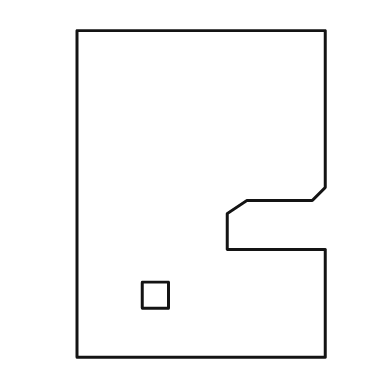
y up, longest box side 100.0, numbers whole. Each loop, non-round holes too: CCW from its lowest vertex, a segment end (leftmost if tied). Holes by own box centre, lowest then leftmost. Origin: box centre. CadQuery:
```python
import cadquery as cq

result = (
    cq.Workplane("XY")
    .moveTo(-38.0, -50.0)
    .lineTo(38.0, -50.0)
    .lineTo(38.0, -17.0)
    .lineTo(8.0, -17.0)
    .lineTo(8.0, -6.0)
    .lineTo(14.0, -2.0)
    .lineTo(34.0, -2.0)
    .lineTo(38.0, 2.0)
    .lineTo(38.0, 50.0)
    .lineTo(-38.0, 50.0)
    .close()
    .moveTo(-18.0, -35.0)
    .lineTo(-10.0, -35.0)
    .lineTo(-10.0, -27.0)
    .lineTo(-18.0, -27.0)
    .close()
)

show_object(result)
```